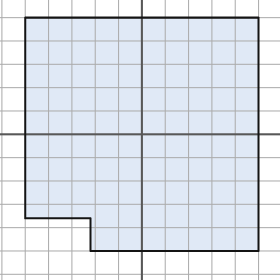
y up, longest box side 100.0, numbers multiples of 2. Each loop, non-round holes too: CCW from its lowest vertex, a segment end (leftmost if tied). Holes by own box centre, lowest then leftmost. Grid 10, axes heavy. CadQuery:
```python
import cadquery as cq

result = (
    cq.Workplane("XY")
    .moveTo(-22.0, -50.0)
    .lineTo(50.0, -50.0)
    .lineTo(50.0, 50.0)
    .lineTo(-50.0, 50.0)
    .lineTo(-50.0, -36.0)
    .lineTo(-22.0, -36.0)
    .close()
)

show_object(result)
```